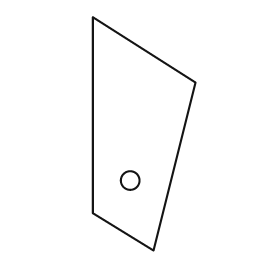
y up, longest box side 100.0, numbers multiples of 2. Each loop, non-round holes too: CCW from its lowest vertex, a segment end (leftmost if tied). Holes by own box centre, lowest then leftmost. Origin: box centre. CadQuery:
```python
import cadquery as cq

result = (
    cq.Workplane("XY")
    .moveTo(4.0, -50.0)
    .lineTo(22.0, 22.0)
    .lineTo(-22.0, 50.0)
    .lineTo(-22.0, -34.0)
    .close()
    .moveTo(-6.0, -20.0)
    .circle(4.0)
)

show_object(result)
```